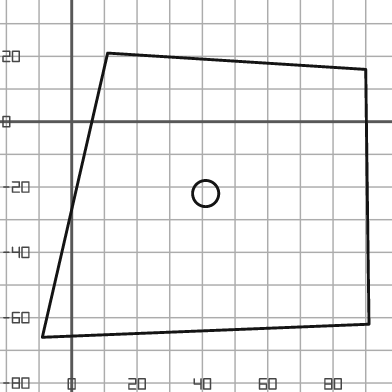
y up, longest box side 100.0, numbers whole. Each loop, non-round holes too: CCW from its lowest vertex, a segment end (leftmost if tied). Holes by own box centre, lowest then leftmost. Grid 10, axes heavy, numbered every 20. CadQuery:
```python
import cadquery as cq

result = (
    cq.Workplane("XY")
    .moveTo(-9.0, -66.0)
    .lineTo(91.0, -62.0)
    .lineTo(90.0, 16.0)
    .lineTo(11.0, 21.0)
    .close()
    .moveTo(41.0, -22.0)
    .circle(4.0)
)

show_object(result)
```